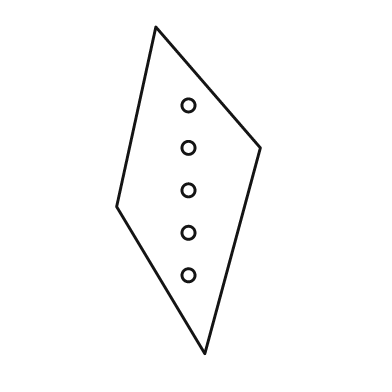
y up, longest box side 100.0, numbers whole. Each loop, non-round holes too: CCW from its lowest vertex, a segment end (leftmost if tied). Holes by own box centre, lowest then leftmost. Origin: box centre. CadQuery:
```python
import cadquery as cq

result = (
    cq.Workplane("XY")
    .moveTo(5.0, -50.0)
    .lineTo(22.0, 13.0)
    .lineTo(-10.0, 50.0)
    .lineTo(-22.0, -5.0)
    .close()
    .moveTo(0.0, -26.0)
    .circle(2.0)
    .moveTo(0.0, -13.0)
    .circle(2.0)
    .moveTo(0.0, 0.0)
    .circle(2.0)
    .moveTo(0.0, 13.0)
    .circle(2.0)
    .moveTo(0.0, 26.0)
    .circle(2.0)
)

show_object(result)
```